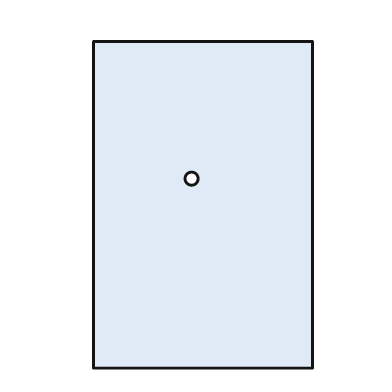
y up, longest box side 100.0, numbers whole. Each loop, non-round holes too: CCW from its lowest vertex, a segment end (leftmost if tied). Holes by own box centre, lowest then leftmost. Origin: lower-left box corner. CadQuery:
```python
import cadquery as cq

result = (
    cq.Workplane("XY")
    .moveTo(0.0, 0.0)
    .lineTo(67.0, 0.0)
    .lineTo(67.0, 100.0)
    .lineTo(0.0, 100.0)
    .close()
    .moveTo(30.0, 58.0)
    .circle(2.0)
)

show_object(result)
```